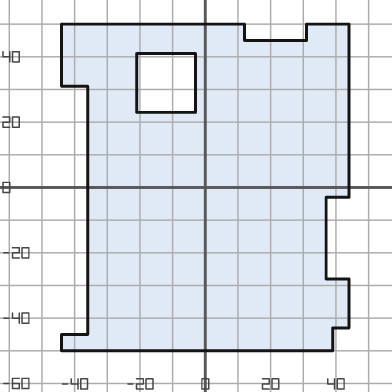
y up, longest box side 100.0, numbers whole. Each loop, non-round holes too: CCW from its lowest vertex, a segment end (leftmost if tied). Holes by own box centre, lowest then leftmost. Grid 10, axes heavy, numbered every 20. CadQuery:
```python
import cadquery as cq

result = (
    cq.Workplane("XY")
    .moveTo(-44.0, -50.0)
    .lineTo(39.0, -50.0)
    .lineTo(39.0, -43.0)
    .lineTo(44.0, -43.0)
    .lineTo(44.0, -28.0)
    .lineTo(37.0, -28.0)
    .lineTo(37.0, -3.0)
    .lineTo(44.0, -3.0)
    .lineTo(44.0, 50.0)
    .lineTo(31.0, 50.0)
    .lineTo(31.0, 45.0)
    .lineTo(12.0, 45.0)
    .lineTo(12.0, 50.0)
    .lineTo(-44.0, 50.0)
    .lineTo(-44.0, 31.0)
    .lineTo(-36.0, 31.0)
    .lineTo(-36.0, -45.0)
    .lineTo(-44.0, -45.0)
    .close()
    .moveTo(-21.0, 23.0)
    .lineTo(-3.0, 23.0)
    .lineTo(-3.0, 41.0)
    .lineTo(-21.0, 41.0)
    .close()
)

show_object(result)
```